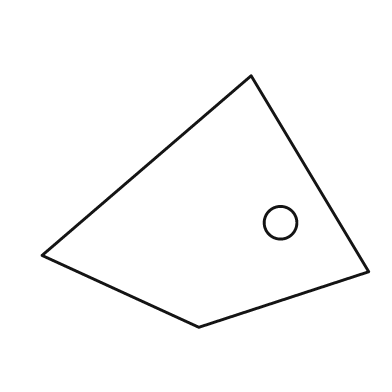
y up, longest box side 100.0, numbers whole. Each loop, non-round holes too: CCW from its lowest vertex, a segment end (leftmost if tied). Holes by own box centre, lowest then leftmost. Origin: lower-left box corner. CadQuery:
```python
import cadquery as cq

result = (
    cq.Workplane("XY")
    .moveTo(48.0, 0.0)
    .lineTo(100.0, 17.0)
    .lineTo(64.0, 77.0)
    .lineTo(0.0, 22.0)
    .close()
    .moveTo(73.0, 32.0)
    .circle(5.0)
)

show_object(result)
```